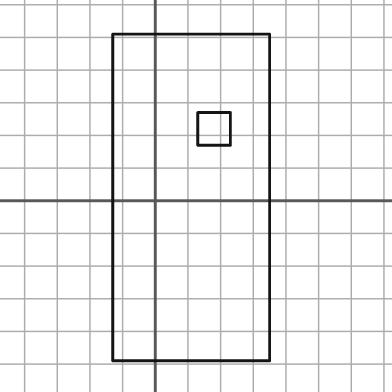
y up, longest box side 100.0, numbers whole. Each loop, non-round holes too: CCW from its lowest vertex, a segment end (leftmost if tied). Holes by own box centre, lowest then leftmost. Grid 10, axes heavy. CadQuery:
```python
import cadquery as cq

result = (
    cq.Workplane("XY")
    .moveTo(-13.0, -49.0)
    .lineTo(35.0, -49.0)
    .lineTo(35.0, 51.0)
    .lineTo(-13.0, 51.0)
    .close()
    .moveTo(13.0, 17.0)
    .lineTo(23.0, 17.0)
    .lineTo(23.0, 27.0)
    .lineTo(13.0, 27.0)
    .close()
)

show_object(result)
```